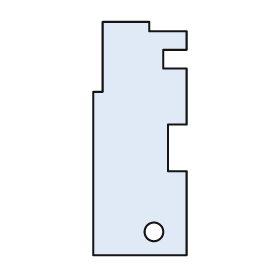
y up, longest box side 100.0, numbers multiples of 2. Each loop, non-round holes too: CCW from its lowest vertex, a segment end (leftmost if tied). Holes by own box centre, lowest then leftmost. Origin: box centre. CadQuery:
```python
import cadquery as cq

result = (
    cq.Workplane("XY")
    .moveTo(-20.0, -50.0)
    .lineTo(20.0, -50.0)
    .lineTo(20.0, -14.0)
    .lineTo(12.0, -14.0)
    .lineTo(12.0, 6.0)
    .lineTo(20.0, 6.0)
    .lineTo(20.0, 30.0)
    .lineTo(10.0, 30.0)
    .lineTo(10.0, 38.0)
    .lineTo(20.0, 38.0)
    .lineTo(20.0, 46.0)
    .lineTo(4.0, 46.0)
    .lineTo(4.0, 50.0)
    .lineTo(-16.0, 50.0)
    .lineTo(-16.0, 20.0)
    .lineTo(-20.0, 20.0)
    .close()
    .moveTo(6.0, -40.0)
    .circle(4.0)
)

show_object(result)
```